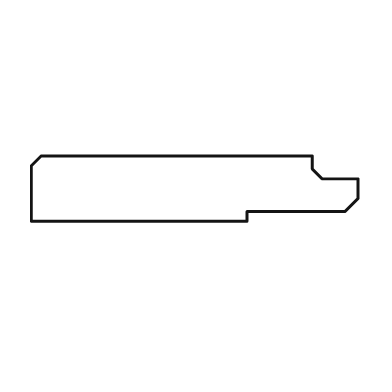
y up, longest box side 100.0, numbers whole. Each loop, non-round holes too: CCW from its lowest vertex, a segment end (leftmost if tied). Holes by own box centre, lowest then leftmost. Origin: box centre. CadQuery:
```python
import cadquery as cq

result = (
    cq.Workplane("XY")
    .moveTo(-50.0, -10.0)
    .lineTo(16.0, -10.0)
    .lineTo(16.0, -7.0)
    .lineTo(46.0, -7.0)
    .lineTo(50.0, -3.0)
    .lineTo(50.0, 3.0)
    .lineTo(39.0, 3.0)
    .lineTo(36.0, 6.0)
    .lineTo(36.0, 10.0)
    .lineTo(-47.0, 10.0)
    .lineTo(-50.0, 7.0)
    .close()
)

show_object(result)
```